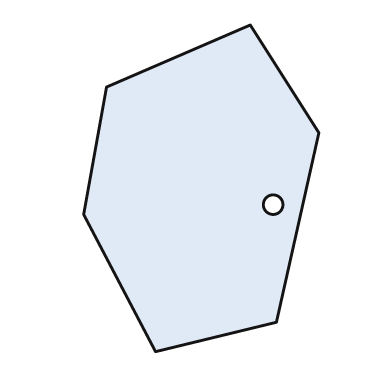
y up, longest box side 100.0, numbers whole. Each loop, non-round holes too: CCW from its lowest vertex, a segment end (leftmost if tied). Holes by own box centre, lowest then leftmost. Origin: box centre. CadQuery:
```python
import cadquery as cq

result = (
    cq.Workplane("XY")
    .moveTo(-14.0, -50.0)
    .lineTo(23.0, -41.0)
    .lineTo(36.0, 17.0)
    .lineTo(15.0, 50.0)
    .lineTo(-29.0, 31.0)
    .lineTo(-36.0, -8.0)
    .close()
    .moveTo(22.0, -5.0)
    .circle(3.0)
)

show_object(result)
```